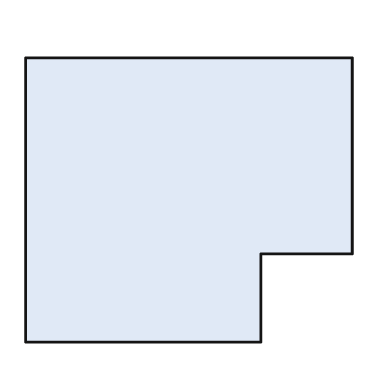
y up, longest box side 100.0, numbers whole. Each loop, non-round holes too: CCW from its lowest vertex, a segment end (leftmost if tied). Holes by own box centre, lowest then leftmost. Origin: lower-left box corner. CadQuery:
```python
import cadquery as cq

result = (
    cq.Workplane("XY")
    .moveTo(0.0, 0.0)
    .lineTo(72.0, 0.0)
    .lineTo(72.0, 27.0)
    .lineTo(100.0, 27.0)
    .lineTo(100.0, 87.0)
    .lineTo(0.0, 87.0)
    .close()
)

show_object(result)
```